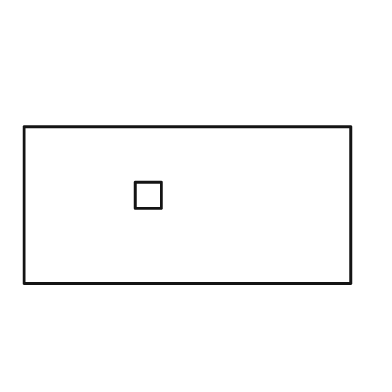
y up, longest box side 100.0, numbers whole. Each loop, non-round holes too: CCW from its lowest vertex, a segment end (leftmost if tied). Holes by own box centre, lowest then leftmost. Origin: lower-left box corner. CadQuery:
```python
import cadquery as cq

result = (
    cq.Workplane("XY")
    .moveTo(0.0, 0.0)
    .lineTo(100.0, 0.0)
    .lineTo(100.0, 48.0)
    .lineTo(0.0, 48.0)
    .close()
    .moveTo(34.0, 23.0)
    .lineTo(42.0, 23.0)
    .lineTo(42.0, 31.0)
    .lineTo(34.0, 31.0)
    .close()
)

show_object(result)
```